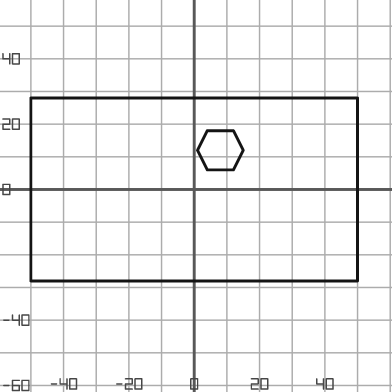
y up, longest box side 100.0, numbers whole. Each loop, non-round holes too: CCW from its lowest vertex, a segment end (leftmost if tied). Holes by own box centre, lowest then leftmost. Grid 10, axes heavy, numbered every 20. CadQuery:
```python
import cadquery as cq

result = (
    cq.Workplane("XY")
    .moveTo(-50.0, -28.0)
    .lineTo(50.0, -28.0)
    .lineTo(50.0, 28.0)
    .lineTo(-50.0, 28.0)
    .close()
    .moveTo(4.0, 6.0)
    .lineTo(12.0, 6.0)
    .lineTo(15.0, 12.0)
    .lineTo(12.0, 18.0)
    .lineTo(4.0, 18.0)
    .lineTo(1.0, 12.0)
    .close()
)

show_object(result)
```